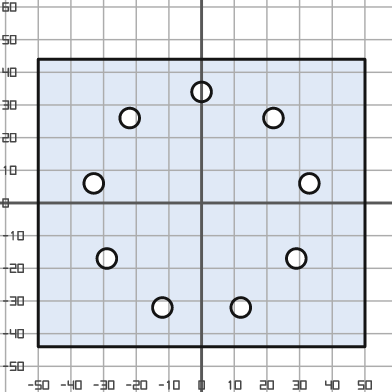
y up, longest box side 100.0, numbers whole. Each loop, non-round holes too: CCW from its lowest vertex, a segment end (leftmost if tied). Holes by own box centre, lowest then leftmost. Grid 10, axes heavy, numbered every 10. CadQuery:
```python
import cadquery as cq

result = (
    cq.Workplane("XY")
    .moveTo(-50.0, -44.0)
    .lineTo(50.0, -44.0)
    .lineTo(50.0, 44.0)
    .lineTo(-50.0, 44.0)
    .close()
    .moveTo(-12.0, -32.0)
    .circle(3.0)
    .moveTo(12.0, -32.0)
    .circle(3.0)
    .moveTo(-29.0, -17.0)
    .circle(3.0)
    .moveTo(29.0, -17.0)
    .circle(3.0)
    .moveTo(-33.0, 6.0)
    .circle(3.0)
    .moveTo(33.0, 6.0)
    .circle(3.0)
    .moveTo(-22.0, 26.0)
    .circle(3.0)
    .moveTo(22.0, 26.0)
    .circle(3.0)
    .moveTo(0.0, 34.0)
    .circle(3.0)
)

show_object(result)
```